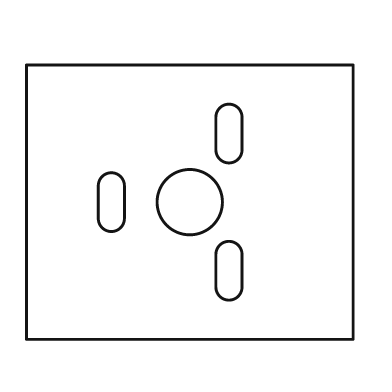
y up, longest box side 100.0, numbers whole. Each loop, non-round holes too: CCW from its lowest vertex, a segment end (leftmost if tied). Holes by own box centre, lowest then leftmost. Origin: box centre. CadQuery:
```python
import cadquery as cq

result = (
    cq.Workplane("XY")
    .moveTo(-50.0, -42.0)
    .lineTo(50.0, -42.0)
    .lineTo(50.0, 42.0)
    .lineTo(-50.0, 42.0)
    .close()
    .moveTo(8.0, -26.0)
    .threePointArc((12.0, -30.0), (16.0, -26.0))
    .lineTo(16.0, -16.0)
    .threePointArc((12.0, -12.0), (8.0, -16.0))
    .close()
    .moveTo(-28.0, -5.0)
    .threePointArc((-24.0, -9.0), (-20.0, -5.0))
    .lineTo(-20.0, 5.0)
    .threePointArc((-24.0, 9.0), (-28.0, 5.0))
    .close()
    .moveTo(0.0, 0.0)
    .circle(10.0)
    .moveTo(8.0, 16.0)
    .threePointArc((12.0, 12.0), (16.0, 16.0))
    .lineTo(16.0, 26.0)
    .threePointArc((12.0, 30.0), (8.0, 26.0))
    .close()
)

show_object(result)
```